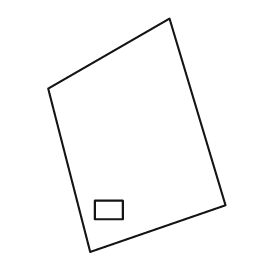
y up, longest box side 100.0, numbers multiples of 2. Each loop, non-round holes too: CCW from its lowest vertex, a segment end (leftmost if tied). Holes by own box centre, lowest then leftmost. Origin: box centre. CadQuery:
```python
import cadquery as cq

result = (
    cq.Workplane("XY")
    .moveTo(-20.0, -50.0)
    .lineTo(38.0, -30.0)
    .lineTo(14.0, 50.0)
    .lineTo(-38.0, 20.0)
    .close()
    .moveTo(-18.0, -36.0)
    .lineTo(-6.0, -36.0)
    .lineTo(-6.0, -28.0)
    .lineTo(-18.0, -28.0)
    .close()
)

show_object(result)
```